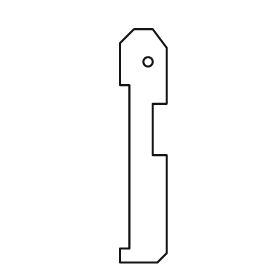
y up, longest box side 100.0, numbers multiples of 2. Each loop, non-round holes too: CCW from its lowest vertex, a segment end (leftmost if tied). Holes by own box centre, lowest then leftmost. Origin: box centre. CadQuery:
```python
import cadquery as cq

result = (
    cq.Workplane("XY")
    .moveTo(-10.0, -50.0)
    .lineTo(6.0, -50.0)
    .lineTo(10.0, -46.0)
    .lineTo(10.0, -4.0)
    .lineTo(4.0, -4.0)
    .lineTo(4.0, 18.0)
    .lineTo(10.0, 18.0)
    .lineTo(10.0, 42.0)
    .lineTo(4.0, 50.0)
    .lineTo(-4.0, 50.0)
    .lineTo(-10.0, 44.0)
    .lineTo(-10.0, 26.0)
    .lineTo(-6.0, 26.0)
    .lineTo(-6.0, -44.0)
    .lineTo(-10.0, -44.0)
    .close()
    .moveTo(2.0, 36.0)
    .circle(2.0)
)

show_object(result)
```